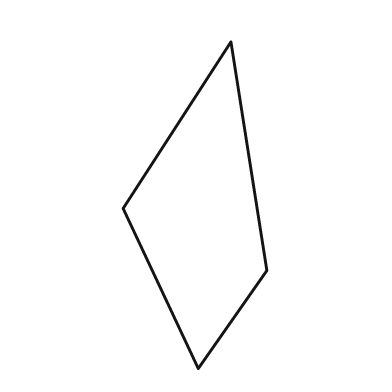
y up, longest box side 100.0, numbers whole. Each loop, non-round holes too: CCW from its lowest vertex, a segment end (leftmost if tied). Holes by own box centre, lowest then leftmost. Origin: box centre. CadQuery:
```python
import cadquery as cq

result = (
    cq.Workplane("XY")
    .moveTo(1.0, -50.0)
    .lineTo(22.0, -20.0)
    .lineTo(11.0, 50.0)
    .lineTo(-22.0, -1.0)
    .close()
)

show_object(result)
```